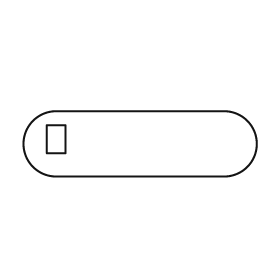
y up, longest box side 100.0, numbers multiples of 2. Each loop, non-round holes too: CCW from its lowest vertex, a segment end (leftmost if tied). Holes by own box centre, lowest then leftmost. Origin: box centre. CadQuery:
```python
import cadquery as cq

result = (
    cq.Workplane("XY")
    .moveTo(-36.0, -14.0)
    .lineTo(36.0, -14.0)
    .threePointArc((50.0, 0.0), (36.0, 14.0))
    .lineTo(-36.0, 14.0)
    .threePointArc((-50.0, 0.0), (-36.0, -14.0))
    .close()
    .moveTo(-40.0, -4.0)
    .lineTo(-32.0, -4.0)
    .lineTo(-32.0, 8.0)
    .lineTo(-40.0, 8.0)
    .close()
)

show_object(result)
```